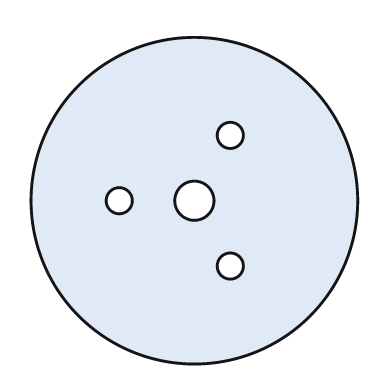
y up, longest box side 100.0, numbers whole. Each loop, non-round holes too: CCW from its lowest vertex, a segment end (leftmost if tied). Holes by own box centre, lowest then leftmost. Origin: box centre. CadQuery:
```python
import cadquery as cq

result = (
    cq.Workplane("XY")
    .moveTo(0.0, 0.0)
    .circle(50.0)
    .moveTo(11.0, -20.0)
    .circle(4.0)
    .moveTo(-23.0, 0.0)
    .circle(4.0)
    .moveTo(0.0, 0.0)
    .circle(6.0)
    .moveTo(11.0, 20.0)
    .circle(4.0)
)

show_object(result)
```